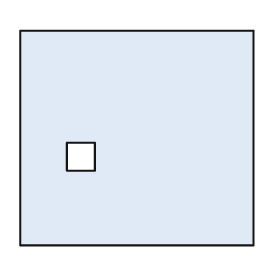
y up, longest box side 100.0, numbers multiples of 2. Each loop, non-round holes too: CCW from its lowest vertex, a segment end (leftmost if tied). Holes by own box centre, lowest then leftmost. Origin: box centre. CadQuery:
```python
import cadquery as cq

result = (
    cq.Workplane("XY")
    .moveTo(-50.0, -46.0)
    .lineTo(50.0, -46.0)
    .lineTo(50.0, 46.0)
    .lineTo(-50.0, 46.0)
    .close()
    .moveTo(-30.0, -14.0)
    .lineTo(-18.0, -14.0)
    .lineTo(-18.0, -2.0)
    .lineTo(-30.0, -2.0)
    .close()
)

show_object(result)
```